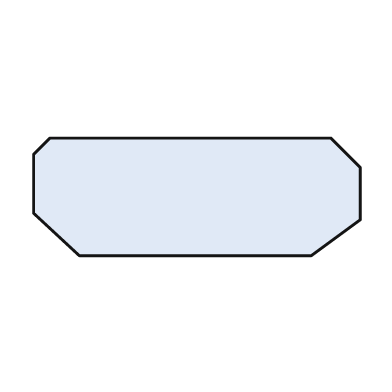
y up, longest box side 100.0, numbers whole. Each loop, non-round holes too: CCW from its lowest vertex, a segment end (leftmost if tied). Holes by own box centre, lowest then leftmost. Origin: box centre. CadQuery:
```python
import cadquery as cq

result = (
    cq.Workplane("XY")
    .moveTo(-36.0, -18.0)
    .lineTo(35.0, -18.0)
    .lineTo(50.0, -7.0)
    .lineTo(50.0, 9.0)
    .lineTo(41.0, 18.0)
    .lineTo(-45.0, 18.0)
    .lineTo(-50.0, 13.0)
    .lineTo(-50.0, -5.0)
    .close()
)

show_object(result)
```